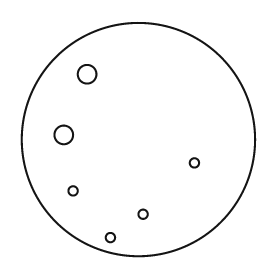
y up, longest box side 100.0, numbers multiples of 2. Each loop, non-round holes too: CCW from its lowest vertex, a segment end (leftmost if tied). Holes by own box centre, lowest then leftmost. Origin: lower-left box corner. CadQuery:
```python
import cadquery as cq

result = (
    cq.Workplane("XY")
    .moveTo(50.0, 50.0)
    .circle(50.0)
    .moveTo(38.0, 8.0)
    .circle(2.0)
    .moveTo(52.0, 18.0)
    .circle(2.0)
    .moveTo(22.0, 28.0)
    .circle(2.0)
    .moveTo(74.0, 40.0)
    .circle(2.0)
    .moveTo(18.0, 52.0)
    .circle(4.0)
    .moveTo(28.0, 78.0)
    .circle(4.0)
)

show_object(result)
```